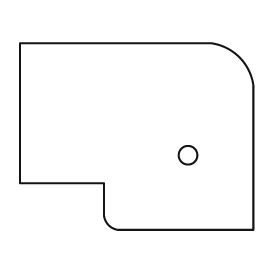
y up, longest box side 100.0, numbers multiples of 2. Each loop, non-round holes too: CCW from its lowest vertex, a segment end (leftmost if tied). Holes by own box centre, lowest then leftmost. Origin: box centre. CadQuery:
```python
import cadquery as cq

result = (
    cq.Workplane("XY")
    .moveTo(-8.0, -40.0)
    .lineTo(50.0, -40.0)
    .lineTo(50.0, 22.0)
    .threePointArc((44.0, 34.0), (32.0, 40.0))
    .lineTo(-50.0, 40.0)
    .lineTo(-50.0, -20.0)
    .lineTo(-14.0, -20.0)
    .lineTo(-14.0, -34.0)
    .threePointArc((-12.0, -38.0), (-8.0, -40.0))
    .close()
    .moveTo(22.0, -8.0)
    .circle(4.0)
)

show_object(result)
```